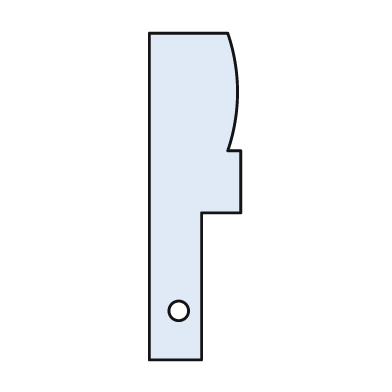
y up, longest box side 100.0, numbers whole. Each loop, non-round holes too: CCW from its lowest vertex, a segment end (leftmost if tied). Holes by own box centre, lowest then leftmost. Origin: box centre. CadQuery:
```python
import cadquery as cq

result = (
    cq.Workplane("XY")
    .moveTo(-14.0, -50.0)
    .lineTo(2.0, -50.0)
    .lineTo(2.0, -5.0)
    .lineTo(14.0, -5.0)
    .lineTo(14.0, 14.0)
    .lineTo(10.0, 14.0)
    .threePointArc((13.0, 32.0), (10.0, 50.0))
    .lineTo(-14.0, 50.0)
    .close()
    .moveTo(-5.0, -35.0)
    .circle(3.0)
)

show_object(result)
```